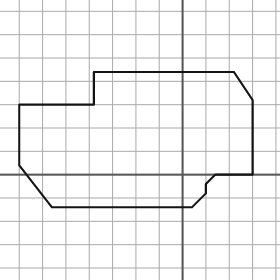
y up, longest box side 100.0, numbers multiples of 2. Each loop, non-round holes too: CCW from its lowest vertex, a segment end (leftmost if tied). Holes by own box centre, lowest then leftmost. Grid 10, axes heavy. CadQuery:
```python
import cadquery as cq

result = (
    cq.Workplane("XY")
    .moveTo(-56.0, -14.0)
    .lineTo(4.0, -14.0)
    .lineTo(10.0, -8.0)
    .lineTo(10.0, -4.0)
    .lineTo(14.0, 0.0)
    .lineTo(30.0, 0.0)
    .lineTo(30.0, 32.0)
    .lineTo(22.0, 44.0)
    .lineTo(-38.0, 44.0)
    .lineTo(-38.0, 30.0)
    .lineTo(-70.0, 30.0)
    .lineTo(-70.0, 4.0)
    .close()
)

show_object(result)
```